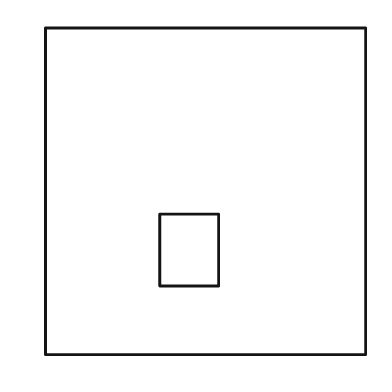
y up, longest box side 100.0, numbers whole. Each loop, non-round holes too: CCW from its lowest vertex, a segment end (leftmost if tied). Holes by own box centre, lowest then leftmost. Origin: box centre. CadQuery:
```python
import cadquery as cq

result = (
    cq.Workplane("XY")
    .moveTo(-49.0, -50.0)
    .lineTo(49.0, -50.0)
    .lineTo(49.0, 50.0)
    .lineTo(-49.0, 50.0)
    .close()
    .moveTo(-14.0, -29.0)
    .lineTo(4.0, -29.0)
    .lineTo(4.0, -7.0)
    .lineTo(-14.0, -7.0)
    .close()
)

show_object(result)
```